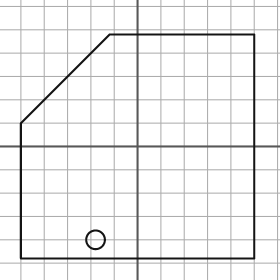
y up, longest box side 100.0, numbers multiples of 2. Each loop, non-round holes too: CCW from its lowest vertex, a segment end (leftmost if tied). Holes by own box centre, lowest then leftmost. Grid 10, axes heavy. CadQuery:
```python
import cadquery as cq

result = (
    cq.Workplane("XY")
    .moveTo(-50.0, -48.0)
    .lineTo(50.0, -48.0)
    .lineTo(50.0, 48.0)
    .lineTo(-12.0, 48.0)
    .lineTo(-50.0, 10.0)
    .close()
    .moveTo(-18.0, -40.0)
    .circle(4.0)
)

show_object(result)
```